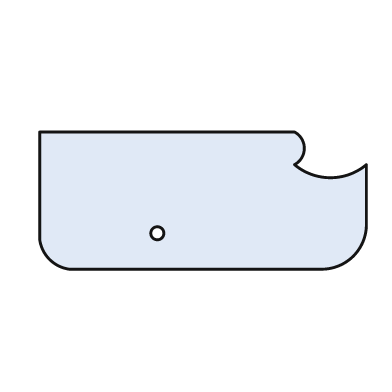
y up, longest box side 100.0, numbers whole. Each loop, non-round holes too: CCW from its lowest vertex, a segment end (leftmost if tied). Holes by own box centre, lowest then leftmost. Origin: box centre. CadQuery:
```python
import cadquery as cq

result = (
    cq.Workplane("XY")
    .moveTo(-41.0, -21.0)
    .lineTo(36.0, -21.0)
    .threePointArc((46.0, -17.0), (50.0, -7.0))
    .lineTo(50.0, 11.0)
    .threePointArc((39.0, 7.0), (28.0, 11.0))
    .threePointArc((31.0, 16.0), (28.0, 21.0))
    .lineTo(-50.0, 21.0)
    .lineTo(-50.0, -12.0)
    .threePointArc((-47.0, -18.0), (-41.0, -21.0))
    .close()
    .moveTo(-14.0, -10.0)
    .circle(2.0)
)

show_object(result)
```